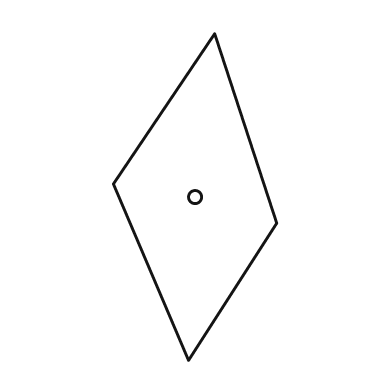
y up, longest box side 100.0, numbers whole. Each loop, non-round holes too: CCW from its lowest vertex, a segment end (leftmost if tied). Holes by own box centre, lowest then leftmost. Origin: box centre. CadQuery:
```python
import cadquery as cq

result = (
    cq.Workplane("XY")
    .moveTo(-2.0, -50.0)
    .lineTo(25.0, -8.0)
    .lineTo(6.0, 50.0)
    .lineTo(-25.0, 4.0)
    .close()
    .moveTo(0.0, 0.0)
    .circle(2.0)
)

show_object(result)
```